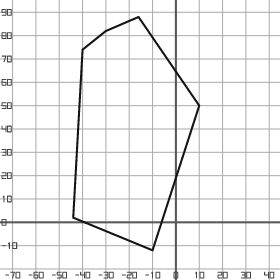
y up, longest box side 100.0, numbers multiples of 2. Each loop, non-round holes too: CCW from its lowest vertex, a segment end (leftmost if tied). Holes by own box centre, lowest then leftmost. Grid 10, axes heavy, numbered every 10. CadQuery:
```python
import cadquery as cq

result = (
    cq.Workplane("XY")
    .moveTo(-10.0, -12.0)
    .lineTo(10.0, 50.0)
    .lineTo(-16.0, 88.0)
    .lineTo(-30.0, 82.0)
    .lineTo(-40.0, 74.0)
    .lineTo(-44.0, 2.0)
    .close()
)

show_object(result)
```